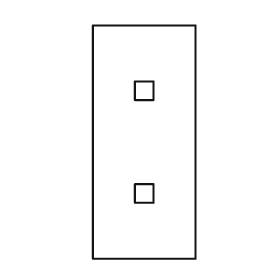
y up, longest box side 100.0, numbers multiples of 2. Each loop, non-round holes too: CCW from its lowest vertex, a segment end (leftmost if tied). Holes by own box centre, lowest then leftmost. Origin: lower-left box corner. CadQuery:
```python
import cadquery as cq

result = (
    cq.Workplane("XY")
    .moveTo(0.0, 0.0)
    .lineTo(44.0, 0.0)
    .lineTo(44.0, 100.0)
    .lineTo(0.0, 100.0)
    .close()
    .moveTo(18.0, 24.0)
    .lineTo(26.0, 24.0)
    .lineTo(26.0, 32.0)
    .lineTo(18.0, 32.0)
    .close()
    .moveTo(18.0, 68.0)
    .lineTo(26.0, 68.0)
    .lineTo(26.0, 76.0)
    .lineTo(18.0, 76.0)
    .close()
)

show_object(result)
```